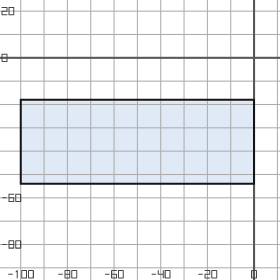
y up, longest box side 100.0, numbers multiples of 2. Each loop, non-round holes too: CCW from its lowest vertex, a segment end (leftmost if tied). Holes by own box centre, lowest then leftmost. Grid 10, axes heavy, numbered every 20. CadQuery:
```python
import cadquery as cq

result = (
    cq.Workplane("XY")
    .moveTo(-100.0, -54.0)
    .lineTo(0.0, -54.0)
    .lineTo(0.0, -18.0)
    .lineTo(-100.0, -18.0)
    .close()
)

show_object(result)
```